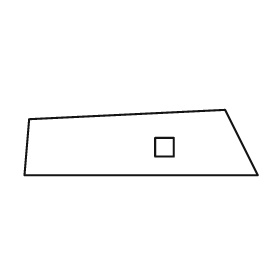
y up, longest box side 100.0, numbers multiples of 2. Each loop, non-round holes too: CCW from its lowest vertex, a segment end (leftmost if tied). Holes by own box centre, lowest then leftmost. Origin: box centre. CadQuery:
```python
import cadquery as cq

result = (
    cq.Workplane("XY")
    .moveTo(-50.0, -14.0)
    .lineTo(50.0, -14.0)
    .lineTo(36.0, 14.0)
    .lineTo(-48.0, 10.0)
    .close()
    .moveTo(6.0, -6.0)
    .lineTo(14.0, -6.0)
    .lineTo(14.0, 2.0)
    .lineTo(6.0, 2.0)
    .close()
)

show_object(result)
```